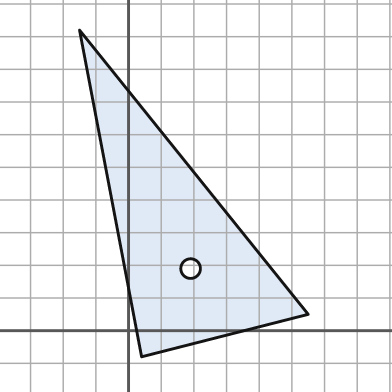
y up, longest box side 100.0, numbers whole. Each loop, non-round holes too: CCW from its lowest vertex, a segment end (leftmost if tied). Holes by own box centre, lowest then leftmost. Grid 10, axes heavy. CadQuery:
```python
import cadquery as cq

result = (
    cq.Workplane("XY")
    .moveTo(4.0, -8.0)
    .lineTo(55.0, 5.0)
    .lineTo(-15.0, 92.0)
    .close()
    .moveTo(19.0, 19.0)
    .circle(3.0)
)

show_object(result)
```